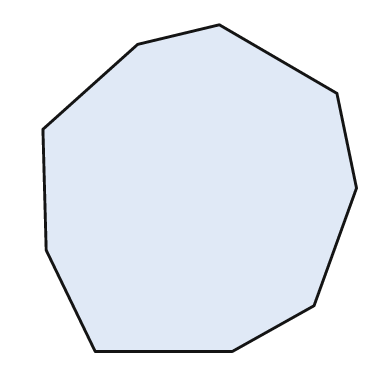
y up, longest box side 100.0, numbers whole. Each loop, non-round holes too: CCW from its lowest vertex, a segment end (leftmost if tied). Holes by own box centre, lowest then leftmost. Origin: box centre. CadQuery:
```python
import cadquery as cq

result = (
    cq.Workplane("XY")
    .moveTo(-32.0, -50.0)
    .lineTo(10.0, -50.0)
    .lineTo(35.0, -36.0)
    .lineTo(48.0, 0.0)
    .lineTo(42.0, 29.0)
    .lineTo(6.0, 50.0)
    .lineTo(-19.0, 44.0)
    .lineTo(-48.0, 18.0)
    .lineTo(-47.0, -19.0)
    .close()
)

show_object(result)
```